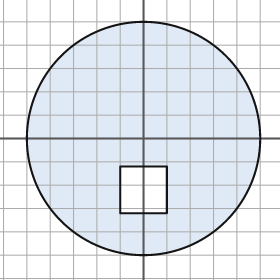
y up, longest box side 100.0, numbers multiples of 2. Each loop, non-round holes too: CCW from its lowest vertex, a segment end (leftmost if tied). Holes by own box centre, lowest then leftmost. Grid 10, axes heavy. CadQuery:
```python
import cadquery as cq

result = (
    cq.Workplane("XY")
    .moveTo(0.0, 0.0)
    .circle(50.0)
    .moveTo(-10.0, -32.0)
    .lineTo(10.0, -32.0)
    .lineTo(10.0, -12.0)
    .lineTo(-10.0, -12.0)
    .close()
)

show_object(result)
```